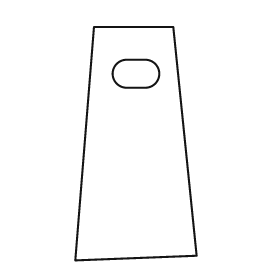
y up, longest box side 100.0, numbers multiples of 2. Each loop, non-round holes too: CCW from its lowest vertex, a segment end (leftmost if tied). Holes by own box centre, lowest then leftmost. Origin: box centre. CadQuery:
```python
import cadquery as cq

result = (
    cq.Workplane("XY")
    .moveTo(-26.0, -50.0)
    .lineTo(26.0, -48.0)
    .lineTo(16.0, 50.0)
    .lineTo(-18.0, 50.0)
    .close()
    .moveTo(-4.0, 24.0)
    .lineTo(4.0, 24.0)
    .threePointArc((10.0, 30.0), (4.0, 36.0))
    .lineTo(-4.0, 36.0)
    .threePointArc((-10.0, 30.0), (-4.0, 24.0))
    .close()
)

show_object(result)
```